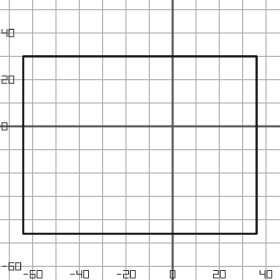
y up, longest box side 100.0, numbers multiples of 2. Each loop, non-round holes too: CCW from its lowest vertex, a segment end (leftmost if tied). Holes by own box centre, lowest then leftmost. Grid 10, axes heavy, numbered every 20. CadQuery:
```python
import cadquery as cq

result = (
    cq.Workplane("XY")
    .moveTo(-64.0, -46.0)
    .lineTo(36.0, -46.0)
    .lineTo(36.0, 30.0)
    .lineTo(-64.0, 30.0)
    .close()
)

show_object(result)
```